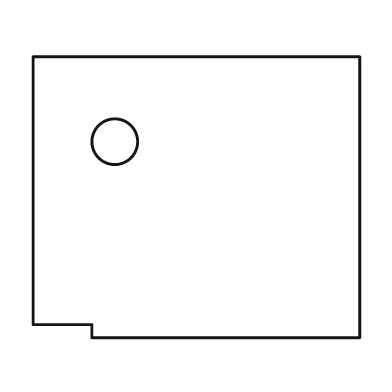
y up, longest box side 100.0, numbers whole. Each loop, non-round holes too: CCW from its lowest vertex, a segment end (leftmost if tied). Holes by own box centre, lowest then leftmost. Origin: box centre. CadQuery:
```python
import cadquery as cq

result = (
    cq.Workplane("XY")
    .moveTo(-32.0, -43.0)
    .lineTo(50.0, -43.0)
    .lineTo(50.0, 43.0)
    .lineTo(-50.0, 43.0)
    .lineTo(-50.0, -39.0)
    .lineTo(-32.0, -39.0)
    .close()
    .moveTo(-25.0, 17.0)
    .circle(7.0)
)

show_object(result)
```